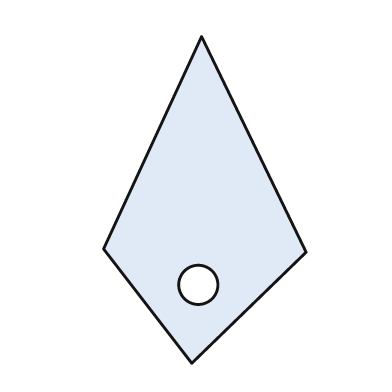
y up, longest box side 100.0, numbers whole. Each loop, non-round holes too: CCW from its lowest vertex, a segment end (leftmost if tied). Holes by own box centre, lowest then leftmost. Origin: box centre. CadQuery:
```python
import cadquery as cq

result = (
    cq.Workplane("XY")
    .moveTo(-4.0, -50.0)
    .lineTo(31.0, -16.0)
    .lineTo(-1.0, 50.0)
    .lineTo(-31.0, -15.0)
    .close()
    .moveTo(-2.0, -26.0)
    .circle(6.0)
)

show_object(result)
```